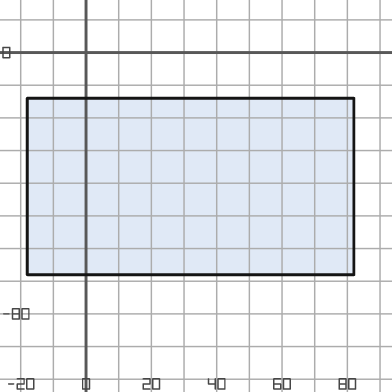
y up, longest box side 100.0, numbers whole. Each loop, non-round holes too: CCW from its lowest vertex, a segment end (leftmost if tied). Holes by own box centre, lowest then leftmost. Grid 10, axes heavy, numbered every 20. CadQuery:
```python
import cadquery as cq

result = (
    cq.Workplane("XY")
    .moveTo(-18.0, -68.0)
    .lineTo(82.0, -68.0)
    .lineTo(82.0, -14.0)
    .lineTo(-18.0, -14.0)
    .close()
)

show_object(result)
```